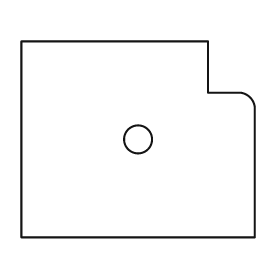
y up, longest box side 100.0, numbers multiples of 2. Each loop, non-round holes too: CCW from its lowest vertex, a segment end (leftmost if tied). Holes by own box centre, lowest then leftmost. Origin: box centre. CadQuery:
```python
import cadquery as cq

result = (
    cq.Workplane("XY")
    .moveTo(-50.0, -42.0)
    .lineTo(50.0, -42.0)
    .lineTo(50.0, 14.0)
    .threePointArc((48.0, 18.0), (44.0, 20.0))
    .lineTo(30.0, 20.0)
    .lineTo(30.0, 42.0)
    .lineTo(-50.0, 42.0)
    .close()
    .moveTo(0.0, 0.0)
    .circle(6.0)
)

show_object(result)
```